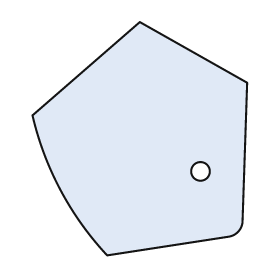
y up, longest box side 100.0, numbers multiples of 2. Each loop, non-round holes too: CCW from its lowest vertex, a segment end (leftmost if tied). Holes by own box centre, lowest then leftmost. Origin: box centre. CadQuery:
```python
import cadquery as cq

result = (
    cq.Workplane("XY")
    .moveTo(-14.0, -50.0)
    .lineTo(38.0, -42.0)
    .threePointArc((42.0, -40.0), (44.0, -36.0))
    .lineTo(46.0, 24.0)
    .lineTo(0.0, 50.0)
    .lineTo(-46.0, 10.0)
    .threePointArc((-34.0, -22.0), (-14.0, -50.0))
    .close()
    .moveTo(26.0, -14.0)
    .circle(4.0)
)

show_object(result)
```